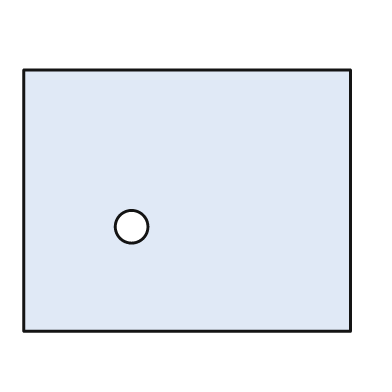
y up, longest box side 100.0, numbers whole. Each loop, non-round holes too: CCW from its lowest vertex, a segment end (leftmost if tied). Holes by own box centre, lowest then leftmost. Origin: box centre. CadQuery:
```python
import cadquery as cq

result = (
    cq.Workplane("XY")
    .moveTo(-50.0, -40.0)
    .lineTo(50.0, -40.0)
    .lineTo(50.0, 40.0)
    .lineTo(-50.0, 40.0)
    .close()
    .moveTo(-17.0, -8.0)
    .circle(5.0)
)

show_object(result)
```